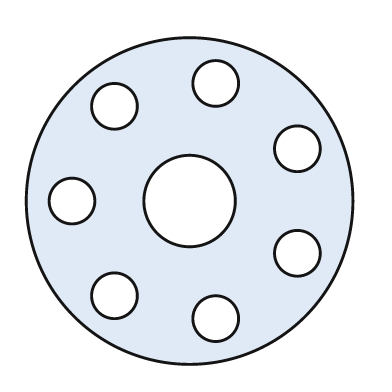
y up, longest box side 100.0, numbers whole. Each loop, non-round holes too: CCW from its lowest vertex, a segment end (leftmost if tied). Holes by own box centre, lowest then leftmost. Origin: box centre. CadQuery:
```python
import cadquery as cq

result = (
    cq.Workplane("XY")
    .moveTo(0.0, 0.0)
    .circle(50.0)
    .moveTo(8.0, -36.0)
    .circle(7.0)
    .moveTo(-23.0, -29.0)
    .circle(7.0)
    .moveTo(33.0, -16.0)
    .circle(7.0)
    .moveTo(-36.0, 0.0)
    .circle(7.0)
    .moveTo(0.0, 0.0)
    .circle(14.0)
    .moveTo(33.0, 16.0)
    .circle(7.0)
    .moveTo(-23.0, 29.0)
    .circle(7.0)
    .moveTo(8.0, 36.0)
    .circle(7.0)
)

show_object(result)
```